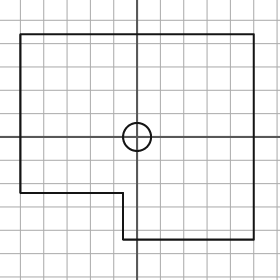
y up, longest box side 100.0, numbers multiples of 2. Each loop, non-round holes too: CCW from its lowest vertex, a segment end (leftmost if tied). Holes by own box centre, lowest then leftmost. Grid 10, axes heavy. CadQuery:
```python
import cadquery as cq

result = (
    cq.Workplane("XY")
    .moveTo(-6.0, -44.0)
    .lineTo(50.0, -44.0)
    .lineTo(50.0, 44.0)
    .lineTo(-50.0, 44.0)
    .lineTo(-50.0, -24.0)
    .lineTo(-6.0, -24.0)
    .close()
    .moveTo(0.0, 0.0)
    .circle(6.0)
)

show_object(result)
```